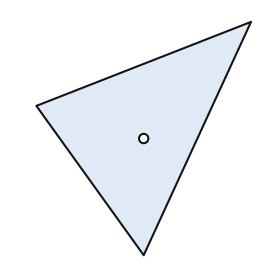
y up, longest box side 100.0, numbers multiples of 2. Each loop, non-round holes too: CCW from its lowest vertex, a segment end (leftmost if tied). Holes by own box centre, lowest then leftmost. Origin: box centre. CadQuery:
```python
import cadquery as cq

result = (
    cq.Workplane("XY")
    .moveTo(0.0, -50.0)
    .lineTo(46.0, 50.0)
    .lineTo(-46.0, 14.0)
    .close()
    .moveTo(0.0, 0.0)
    .circle(2.0)
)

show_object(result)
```